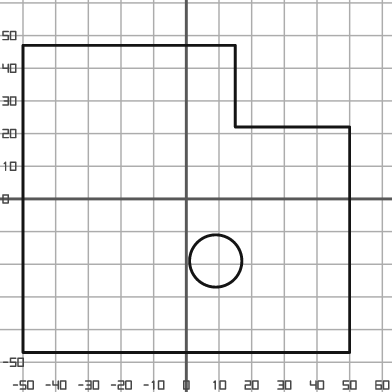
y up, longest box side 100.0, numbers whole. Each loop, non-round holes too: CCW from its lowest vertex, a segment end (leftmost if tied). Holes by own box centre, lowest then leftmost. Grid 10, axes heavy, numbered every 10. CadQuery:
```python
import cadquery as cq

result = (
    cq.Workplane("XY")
    .moveTo(-50.0, -47.0)
    .lineTo(50.0, -47.0)
    .lineTo(50.0, 22.0)
    .lineTo(15.0, 22.0)
    .lineTo(15.0, 47.0)
    .lineTo(-50.0, 47.0)
    .close()
    .moveTo(9.0, -19.0)
    .circle(8.0)
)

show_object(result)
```